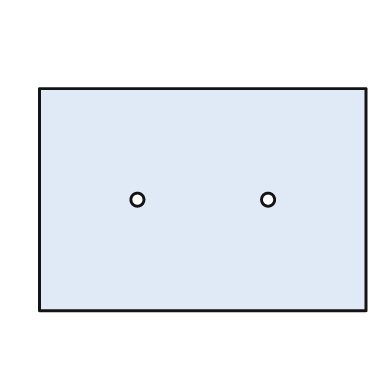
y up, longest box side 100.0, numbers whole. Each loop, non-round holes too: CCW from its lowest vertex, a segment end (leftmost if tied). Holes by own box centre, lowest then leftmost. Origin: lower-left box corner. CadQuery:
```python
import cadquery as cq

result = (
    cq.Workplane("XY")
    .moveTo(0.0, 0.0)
    .lineTo(100.0, 0.0)
    .lineTo(100.0, 68.0)
    .lineTo(0.0, 68.0)
    .close()
    .moveTo(30.0, 34.0)
    .circle(2.0)
    .moveTo(70.0, 34.0)
    .circle(2.0)
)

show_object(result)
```